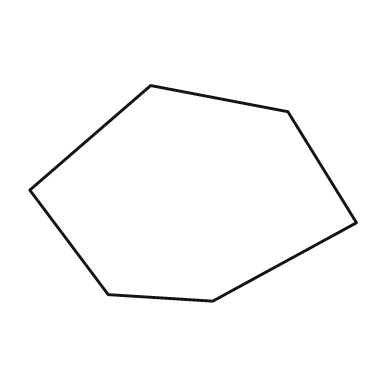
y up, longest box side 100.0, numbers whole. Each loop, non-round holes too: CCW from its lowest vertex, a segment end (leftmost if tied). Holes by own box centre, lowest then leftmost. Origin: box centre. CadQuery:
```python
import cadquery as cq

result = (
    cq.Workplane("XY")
    .moveTo(6.0, -33.0)
    .lineTo(50.0, -9.0)
    .lineTo(29.0, 25.0)
    .lineTo(-13.0, 33.0)
    .lineTo(-50.0, 1.0)
    .lineTo(-26.0, -31.0)
    .close()
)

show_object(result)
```